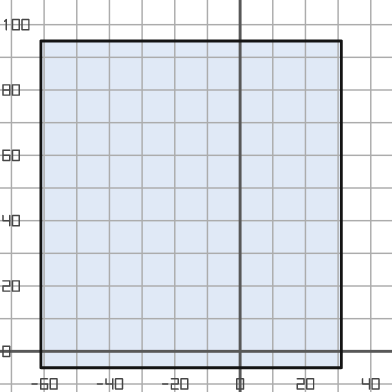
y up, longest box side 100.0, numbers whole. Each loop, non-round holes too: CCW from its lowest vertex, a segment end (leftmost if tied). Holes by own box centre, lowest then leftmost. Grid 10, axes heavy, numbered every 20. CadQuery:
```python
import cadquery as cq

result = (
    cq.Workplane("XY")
    .moveTo(-61.0, -5.0)
    .lineTo(31.0, -5.0)
    .lineTo(31.0, 95.0)
    .lineTo(-61.0, 95.0)
    .close()
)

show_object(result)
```